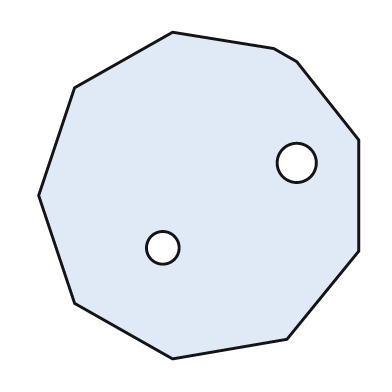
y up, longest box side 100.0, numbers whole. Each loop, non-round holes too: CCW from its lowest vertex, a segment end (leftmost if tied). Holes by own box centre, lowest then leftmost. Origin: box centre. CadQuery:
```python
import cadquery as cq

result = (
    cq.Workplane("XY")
    .moveTo(-8.0, -50.0)
    .lineTo(27.0, -44.0)
    .lineTo(49.0, -17.0)
    .lineTo(49.0, 17.0)
    .lineTo(30.0, 41.0)
    .lineTo(23.0, 45.0)
    .lineTo(-8.0, 50.0)
    .lineTo(-38.0, 33.0)
    .lineTo(-49.0, 0.0)
    .lineTo(-38.0, -33.0)
    .close()
    .moveTo(-11.0, -16.0)
    .circle(5.0)
    .moveTo(30.0, 10.0)
    .circle(6.0)
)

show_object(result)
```